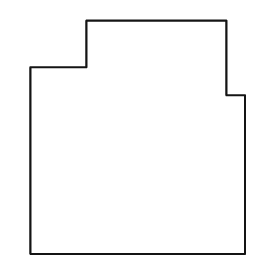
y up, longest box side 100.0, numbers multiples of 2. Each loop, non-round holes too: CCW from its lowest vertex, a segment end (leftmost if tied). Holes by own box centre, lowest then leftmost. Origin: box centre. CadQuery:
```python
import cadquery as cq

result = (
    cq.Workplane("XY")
    .moveTo(-46.0, -50.0)
    .lineTo(46.0, -50.0)
    .lineTo(46.0, 18.0)
    .lineTo(38.0, 18.0)
    .lineTo(38.0, 50.0)
    .lineTo(-22.0, 50.0)
    .lineTo(-22.0, 30.0)
    .lineTo(-46.0, 30.0)
    .close()
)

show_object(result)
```